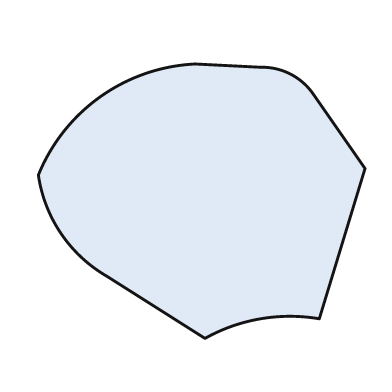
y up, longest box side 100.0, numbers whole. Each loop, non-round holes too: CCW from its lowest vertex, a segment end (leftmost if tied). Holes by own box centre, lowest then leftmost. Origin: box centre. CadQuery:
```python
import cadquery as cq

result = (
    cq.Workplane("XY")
    .moveTo(1.0, -42.0)
    .threePointArc((18.0, -36.0), (36.0, -36.0))
    .lineTo(50.0, 10.0)
    .lineTo(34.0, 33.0)
    .threePointArc((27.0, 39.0), (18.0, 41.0))
    .lineTo(-2.0, 42.0)
    .threePointArc((-31.0, 32.0), (-50.0, 8.0))
    .threePointArc((-43.0, -10.0), (-29.0, -23.0))
    .close()
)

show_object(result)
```